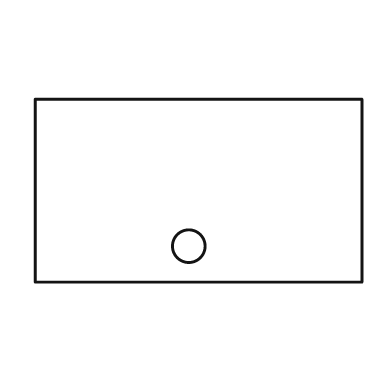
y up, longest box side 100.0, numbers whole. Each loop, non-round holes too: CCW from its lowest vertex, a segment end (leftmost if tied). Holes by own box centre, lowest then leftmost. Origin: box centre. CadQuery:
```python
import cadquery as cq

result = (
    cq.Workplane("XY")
    .moveTo(-50.0, -28.0)
    .lineTo(50.0, -28.0)
    .lineTo(50.0, 28.0)
    .lineTo(-50.0, 28.0)
    .close()
    .moveTo(-3.0, -17.0)
    .circle(5.0)
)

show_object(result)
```